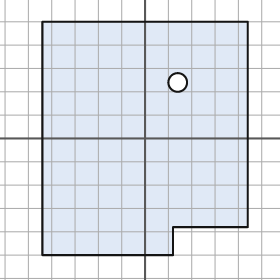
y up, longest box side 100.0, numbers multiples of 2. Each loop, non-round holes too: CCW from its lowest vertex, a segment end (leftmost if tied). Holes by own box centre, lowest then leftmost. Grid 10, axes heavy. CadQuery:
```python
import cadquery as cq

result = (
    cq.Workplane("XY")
    .moveTo(-44.0, -50.0)
    .lineTo(12.0, -50.0)
    .lineTo(12.0, -38.0)
    .lineTo(44.0, -38.0)
    .lineTo(44.0, 50.0)
    .lineTo(-44.0, 50.0)
    .close()
    .moveTo(14.0, 24.0)
    .circle(4.0)
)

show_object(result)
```